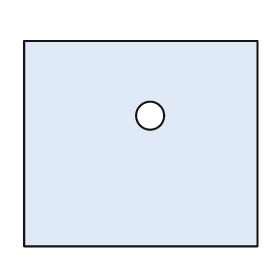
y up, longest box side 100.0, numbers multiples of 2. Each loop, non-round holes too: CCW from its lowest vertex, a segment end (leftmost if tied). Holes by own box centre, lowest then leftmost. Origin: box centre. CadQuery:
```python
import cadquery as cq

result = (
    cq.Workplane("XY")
    .moveTo(-50.0, -44.0)
    .lineTo(50.0, -44.0)
    .lineTo(50.0, 44.0)
    .lineTo(-50.0, 44.0)
    .close()
    .moveTo(4.0, 12.0)
    .circle(6.0)
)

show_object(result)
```